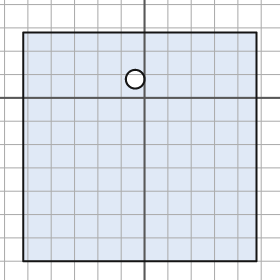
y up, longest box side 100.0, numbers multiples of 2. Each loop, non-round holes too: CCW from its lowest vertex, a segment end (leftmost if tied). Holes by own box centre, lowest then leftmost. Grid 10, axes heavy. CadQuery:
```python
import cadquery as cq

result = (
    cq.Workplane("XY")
    .moveTo(-52.0, -70.0)
    .lineTo(48.0, -70.0)
    .lineTo(48.0, 28.0)
    .lineTo(-52.0, 28.0)
    .close()
    .moveTo(-4.0, 8.0)
    .circle(4.0)
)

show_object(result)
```